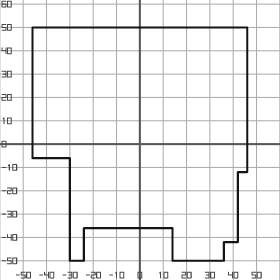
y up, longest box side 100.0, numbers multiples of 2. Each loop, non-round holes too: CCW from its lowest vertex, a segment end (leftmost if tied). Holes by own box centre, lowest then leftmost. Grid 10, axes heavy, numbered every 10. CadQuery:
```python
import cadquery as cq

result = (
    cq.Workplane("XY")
    .moveTo(-30.0, -50.0)
    .lineTo(-24.0, -50.0)
    .lineTo(-24.0, -36.0)
    .lineTo(14.0, -36.0)
    .lineTo(14.0, -50.0)
    .lineTo(36.0, -50.0)
    .lineTo(36.0, -42.0)
    .lineTo(42.0, -42.0)
    .lineTo(42.0, -12.0)
    .lineTo(46.0, -12.0)
    .lineTo(46.0, 50.0)
    .lineTo(-46.0, 50.0)
    .lineTo(-46.0, -6.0)
    .lineTo(-30.0, -6.0)
    .close()
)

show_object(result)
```